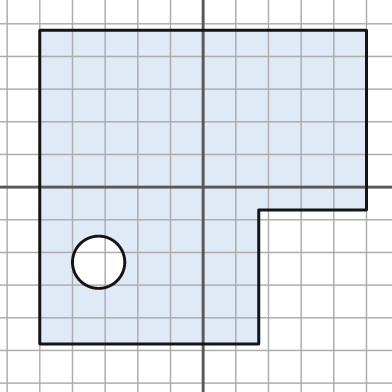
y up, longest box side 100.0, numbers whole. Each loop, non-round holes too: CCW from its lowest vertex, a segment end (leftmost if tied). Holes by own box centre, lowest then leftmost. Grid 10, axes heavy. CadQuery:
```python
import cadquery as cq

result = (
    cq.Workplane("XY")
    .moveTo(-50.0, -48.0)
    .lineTo(17.0, -48.0)
    .lineTo(17.0, -7.0)
    .lineTo(50.0, -7.0)
    .lineTo(50.0, 48.0)
    .lineTo(-50.0, 48.0)
    .close()
    .moveTo(-32.0, -23.0)
    .circle(8.0)
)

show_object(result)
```